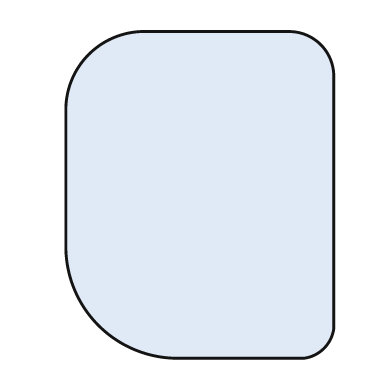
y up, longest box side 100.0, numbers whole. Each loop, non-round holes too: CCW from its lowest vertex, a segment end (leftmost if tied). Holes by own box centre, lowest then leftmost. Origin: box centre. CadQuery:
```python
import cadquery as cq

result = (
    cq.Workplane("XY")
    .moveTo(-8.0, -50.0)
    .lineTo(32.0, -50.0)
    .threePointArc((38.0, -47.0), (41.0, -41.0))
    .lineTo(41.0, 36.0)
    .threePointArc((37.0, 46.0), (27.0, 50.0))
    .lineTo(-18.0, 50.0)
    .threePointArc((-34.0, 43.0), (-41.0, 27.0))
    .lineTo(-41.0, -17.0)
    .threePointArc((-31.0, -40.0), (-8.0, -50.0))
    .close()
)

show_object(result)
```